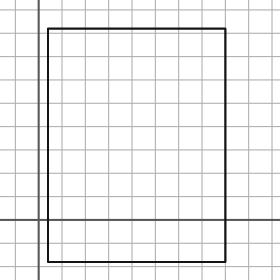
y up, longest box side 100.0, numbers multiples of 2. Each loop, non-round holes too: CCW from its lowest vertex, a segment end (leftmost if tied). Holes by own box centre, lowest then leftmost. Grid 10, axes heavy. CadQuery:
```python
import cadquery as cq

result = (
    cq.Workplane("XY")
    .moveTo(4.0, -18.0)
    .lineTo(80.0, -18.0)
    .lineTo(80.0, 82.0)
    .lineTo(4.0, 82.0)
    .close()
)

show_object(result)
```